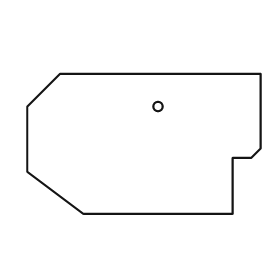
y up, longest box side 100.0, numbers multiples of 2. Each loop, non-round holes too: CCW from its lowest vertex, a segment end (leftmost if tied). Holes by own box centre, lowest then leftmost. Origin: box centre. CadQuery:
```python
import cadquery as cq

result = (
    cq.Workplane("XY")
    .moveTo(-26.0, -30.0)
    .lineTo(38.0, -30.0)
    .lineTo(38.0, -6.0)
    .lineTo(46.0, -6.0)
    .lineTo(50.0, -2.0)
    .lineTo(50.0, 30.0)
    .lineTo(-36.0, 30.0)
    .lineTo(-50.0, 16.0)
    .lineTo(-50.0, -12.0)
    .close()
    .moveTo(6.0, 16.0)
    .circle(2.0)
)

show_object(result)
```